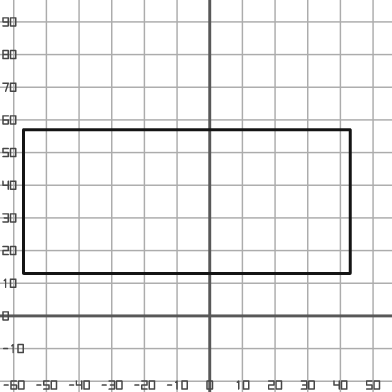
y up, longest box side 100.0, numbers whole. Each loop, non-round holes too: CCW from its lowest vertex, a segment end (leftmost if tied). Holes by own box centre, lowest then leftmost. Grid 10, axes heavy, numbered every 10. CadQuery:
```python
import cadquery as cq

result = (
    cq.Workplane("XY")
    .moveTo(-57.0, 13.0)
    .lineTo(43.0, 13.0)
    .lineTo(43.0, 57.0)
    .lineTo(-57.0, 57.0)
    .close()
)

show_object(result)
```